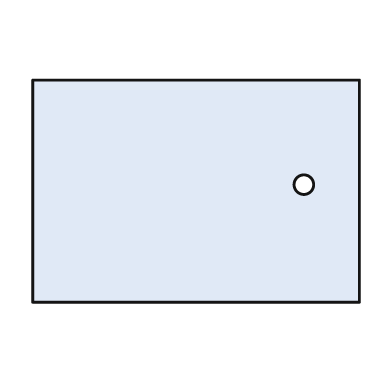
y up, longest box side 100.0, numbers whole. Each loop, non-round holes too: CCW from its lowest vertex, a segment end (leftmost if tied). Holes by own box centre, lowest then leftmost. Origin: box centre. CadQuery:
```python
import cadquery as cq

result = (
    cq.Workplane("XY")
    .moveTo(-50.0, -34.0)
    .lineTo(50.0, -34.0)
    .lineTo(50.0, 34.0)
    .lineTo(-50.0, 34.0)
    .close()
    .moveTo(33.0, 2.0)
    .circle(3.0)
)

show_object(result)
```